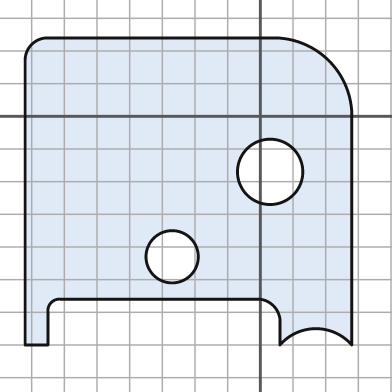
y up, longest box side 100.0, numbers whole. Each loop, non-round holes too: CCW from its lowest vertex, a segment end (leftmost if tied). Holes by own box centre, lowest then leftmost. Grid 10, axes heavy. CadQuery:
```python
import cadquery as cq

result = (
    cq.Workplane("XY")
    .moveTo(-72.0, -70.0)
    .lineTo(-65.0, -70.0)
    .lineTo(-65.0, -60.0)
    .threePointArc((-64.0, -57.0), (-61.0, -56.0))
    .lineTo(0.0, -56.0)
    .threePointArc((4.0, -58.0), (6.0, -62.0))
    .lineTo(6.0, -70.0)
    .threePointArc((17.0, -65.0), (28.0, -70.0))
    .lineTo(28.0, 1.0)
    .threePointArc((21.0, 17.0), (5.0, 24.0))
    .lineTo(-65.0, 24.0)
    .threePointArc((-70.0, 22.0), (-72.0, 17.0))
    .close()
    .moveTo(-27.0, -43.0)
    .circle(8.0)
    .moveTo(3.0, -17.0)
    .circle(10.0)
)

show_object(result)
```